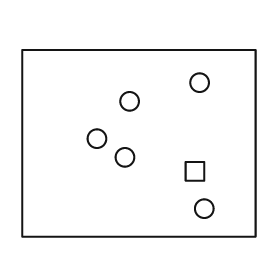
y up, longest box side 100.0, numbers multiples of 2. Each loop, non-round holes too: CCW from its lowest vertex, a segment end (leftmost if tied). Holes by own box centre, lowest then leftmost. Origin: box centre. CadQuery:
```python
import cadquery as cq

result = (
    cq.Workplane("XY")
    .moveTo(-50.0, -40.0)
    .lineTo(50.0, -40.0)
    .lineTo(50.0, 40.0)
    .lineTo(-50.0, 40.0)
    .close()
    .moveTo(28.0, -28.0)
    .circle(4.0)
    .moveTo(20.0, -16.0)
    .lineTo(28.0, -16.0)
    .lineTo(28.0, -8.0)
    .lineTo(20.0, -8.0)
    .close()
    .moveTo(-6.0, -6.0)
    .circle(4.0)
    .moveTo(-18.0, 2.0)
    .circle(4.0)
    .moveTo(-4.0, 18.0)
    .circle(4.0)
    .moveTo(26.0, 26.0)
    .circle(4.0)
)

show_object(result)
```